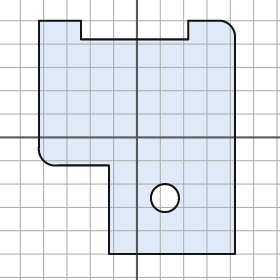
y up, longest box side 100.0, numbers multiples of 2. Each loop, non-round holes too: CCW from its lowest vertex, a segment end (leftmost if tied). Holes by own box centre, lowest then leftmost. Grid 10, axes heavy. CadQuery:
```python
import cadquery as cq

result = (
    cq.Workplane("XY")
    .moveTo(-12.0, -50.0)
    .lineTo(42.0, -50.0)
    .lineTo(42.0, 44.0)
    .threePointArc((40.0, 48.0), (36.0, 50.0))
    .lineTo(22.0, 50.0)
    .lineTo(22.0, 42.0)
    .lineTo(-24.0, 42.0)
    .lineTo(-24.0, 50.0)
    .lineTo(-42.0, 50.0)
    .lineTo(-42.0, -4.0)
    .threePointArc((-40.0, -10.0), (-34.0, -12.0))
    .lineTo(-12.0, -12.0)
    .close()
    .moveTo(12.0, -26.0)
    .circle(6.0)
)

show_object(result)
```